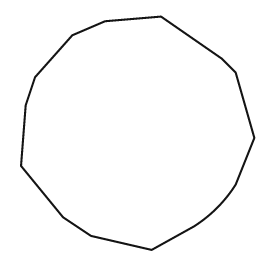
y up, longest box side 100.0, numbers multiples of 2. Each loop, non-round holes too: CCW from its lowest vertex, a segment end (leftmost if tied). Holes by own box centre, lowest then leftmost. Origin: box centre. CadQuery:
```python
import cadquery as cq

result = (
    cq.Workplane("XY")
    .moveTo(6.0, -50.0)
    .lineTo(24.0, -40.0)
    .threePointArc((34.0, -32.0), (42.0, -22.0))
    .lineTo(50.0, -2.0)
    .lineTo(42.0, 26.0)
    .lineTo(36.0, 32.0)
    .lineTo(10.0, 50.0)
    .lineTo(-14.0, 48.0)
    .lineTo(-28.0, 42.0)
    .lineTo(-44.0, 24.0)
    .lineTo(-48.0, 12.0)
    .lineTo(-50.0, -14.0)
    .lineTo(-32.0, -36.0)
    .lineTo(-20.0, -44.0)
    .close()
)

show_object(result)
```